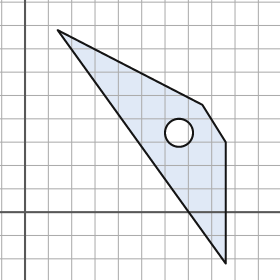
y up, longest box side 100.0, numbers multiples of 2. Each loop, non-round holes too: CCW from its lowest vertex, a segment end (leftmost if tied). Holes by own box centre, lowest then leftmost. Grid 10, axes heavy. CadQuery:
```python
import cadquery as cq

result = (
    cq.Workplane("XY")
    .moveTo(86.0, -22.0)
    .lineTo(86.0, 30.0)
    .lineTo(76.0, 46.0)
    .lineTo(14.0, 78.0)
    .close()
    .moveTo(66.0, 34.0)
    .circle(6.0)
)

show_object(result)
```